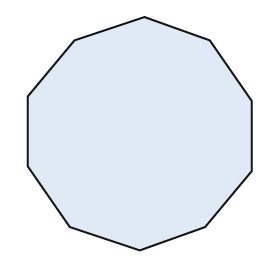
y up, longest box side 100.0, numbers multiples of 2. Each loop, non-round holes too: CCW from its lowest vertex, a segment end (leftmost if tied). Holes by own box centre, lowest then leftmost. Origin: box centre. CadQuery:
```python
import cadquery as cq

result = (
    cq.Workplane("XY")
    .moveTo(0.0, -50.0)
    .lineTo(28.0, -40.0)
    .lineTo(48.0, -16.0)
    .lineTo(48.0, 14.0)
    .lineTo(30.0, 40.0)
    .lineTo(2.0, 50.0)
    .lineTo(-28.0, 40.0)
    .lineTo(-48.0, 16.0)
    .lineTo(-48.0, -14.0)
    .lineTo(-30.0, -40.0)
    .close()
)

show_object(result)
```